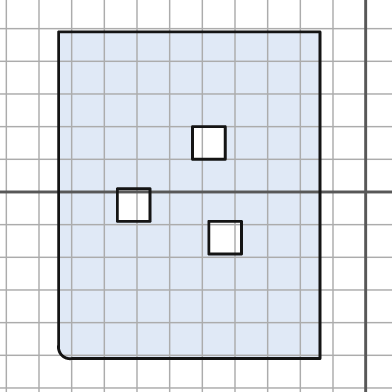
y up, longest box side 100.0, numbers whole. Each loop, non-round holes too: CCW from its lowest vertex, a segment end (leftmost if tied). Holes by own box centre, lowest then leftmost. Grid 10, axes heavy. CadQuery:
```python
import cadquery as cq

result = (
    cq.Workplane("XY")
    .moveTo(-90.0, -51.0)
    .lineTo(-14.0, -51.0)
    .lineTo(-14.0, 49.0)
    .lineTo(-94.0, 49.0)
    .lineTo(-94.0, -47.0)
    .threePointArc((-93.0, -50.0), (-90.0, -51.0))
    .close()
    .moveTo(-48.0, -19.0)
    .lineTo(-38.0, -19.0)
    .lineTo(-38.0, -9.0)
    .lineTo(-48.0, -9.0)
    .close()
    .moveTo(-76.0, -9.0)
    .lineTo(-66.0, -9.0)
    .lineTo(-66.0, 1.0)
    .lineTo(-76.0, 1.0)
    .close()
    .moveTo(-53.0, 10.0)
    .lineTo(-43.0, 10.0)
    .lineTo(-43.0, 20.0)
    .lineTo(-53.0, 20.0)
    .close()
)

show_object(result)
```